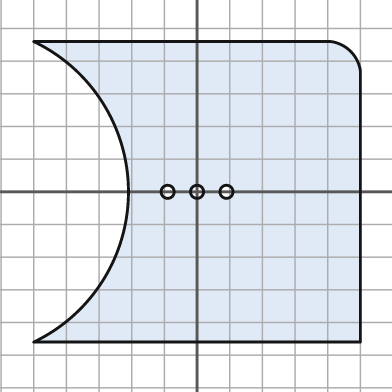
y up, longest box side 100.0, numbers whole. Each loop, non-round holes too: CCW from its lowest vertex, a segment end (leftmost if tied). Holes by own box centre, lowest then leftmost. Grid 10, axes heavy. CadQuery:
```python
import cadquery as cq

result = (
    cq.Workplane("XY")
    .moveTo(-50.0, -46.0)
    .lineTo(50.0, -46.0)
    .lineTo(50.0, 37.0)
    .threePointArc((47.0, 43.0), (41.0, 46.0))
    .lineTo(-50.0, 46.0)
    .threePointArc((-21.0, 0.0), (-50.0, -46.0))
    .close()
    .moveTo(-9.0, 0.0)
    .circle(2.0)
    .moveTo(0.0, 0.0)
    .circle(2.0)
    .moveTo(9.0, 0.0)
    .circle(2.0)
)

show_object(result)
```